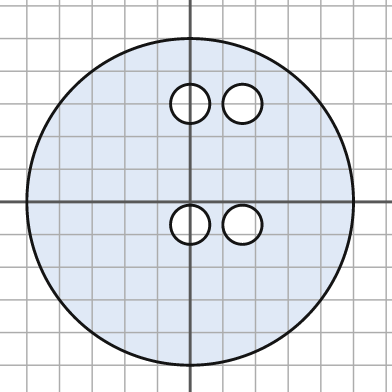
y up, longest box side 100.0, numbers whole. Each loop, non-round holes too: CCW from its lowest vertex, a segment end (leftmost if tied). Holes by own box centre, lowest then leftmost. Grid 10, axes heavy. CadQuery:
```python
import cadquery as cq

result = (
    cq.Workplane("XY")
    .moveTo(0.0, 0.0)
    .circle(50.0)
    .moveTo(0.0, -7.0)
    .circle(6.0)
    .moveTo(16.0, -7.0)
    .circle(6.0)
    .moveTo(0.0, 30.0)
    .circle(6.0)
    .moveTo(16.0, 30.0)
    .circle(6.0)
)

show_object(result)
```